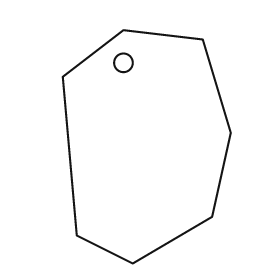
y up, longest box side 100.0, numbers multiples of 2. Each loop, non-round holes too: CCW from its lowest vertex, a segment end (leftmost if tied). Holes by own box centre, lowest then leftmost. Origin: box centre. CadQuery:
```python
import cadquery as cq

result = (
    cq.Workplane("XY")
    .moveTo(-6.0, -50.0)
    .lineTo(28.0, -30.0)
    .lineTo(36.0, 6.0)
    .lineTo(24.0, 46.0)
    .lineTo(-10.0, 50.0)
    .lineTo(-36.0, 30.0)
    .lineTo(-30.0, -38.0)
    .close()
    .moveTo(-10.0, 36.0)
    .circle(4.0)
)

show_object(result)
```